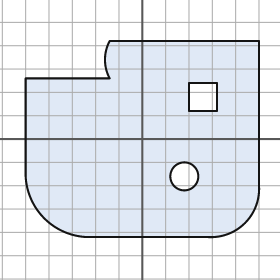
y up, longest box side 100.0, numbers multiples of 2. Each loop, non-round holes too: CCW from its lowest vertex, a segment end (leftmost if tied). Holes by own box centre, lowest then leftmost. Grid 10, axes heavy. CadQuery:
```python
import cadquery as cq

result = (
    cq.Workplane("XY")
    .moveTo(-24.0, -42.0)
    .lineTo(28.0, -42.0)
    .threePointArc((44.0, -36.0), (50.0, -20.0))
    .lineTo(50.0, 42.0)
    .lineTo(-14.0, 42.0)
    .threePointArc((-16.0, 34.0), (-14.0, 26.0))
    .lineTo(-50.0, 26.0)
    .lineTo(-50.0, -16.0)
    .threePointArc((-42.0, -34.0), (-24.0, -42.0))
    .close()
    .moveTo(18.0, -16.0)
    .circle(6.0)
    .moveTo(20.0, 12.0)
    .lineTo(32.0, 12.0)
    .lineTo(32.0, 24.0)
    .lineTo(20.0, 24.0)
    .close()
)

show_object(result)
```